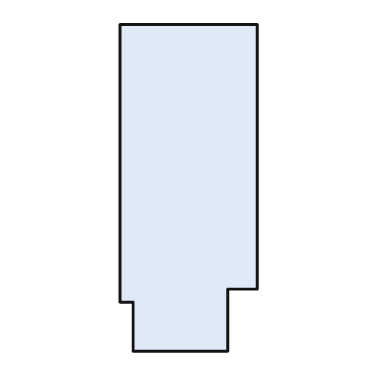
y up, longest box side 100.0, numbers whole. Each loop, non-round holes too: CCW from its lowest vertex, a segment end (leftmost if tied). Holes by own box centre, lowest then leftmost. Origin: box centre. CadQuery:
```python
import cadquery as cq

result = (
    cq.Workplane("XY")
    .moveTo(-17.0, -50.0)
    .lineTo(12.0, -50.0)
    .lineTo(12.0, -31.0)
    .lineTo(21.0, -31.0)
    .lineTo(21.0, 50.0)
    .lineTo(-21.0, 50.0)
    .lineTo(-21.0, -35.0)
    .lineTo(-17.0, -35.0)
    .close()
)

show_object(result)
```